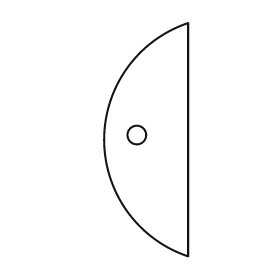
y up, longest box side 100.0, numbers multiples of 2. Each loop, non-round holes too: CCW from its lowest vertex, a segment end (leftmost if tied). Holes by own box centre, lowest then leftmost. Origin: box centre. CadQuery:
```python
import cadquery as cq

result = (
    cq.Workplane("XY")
    .moveTo(18.0, -50.0)
    .lineTo(18.0, 50.0)
    .threePointArc((-18.0, 0.0), (18.0, -50.0))
    .close()
    .moveTo(-4.0, 2.0)
    .circle(4.0)
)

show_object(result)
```